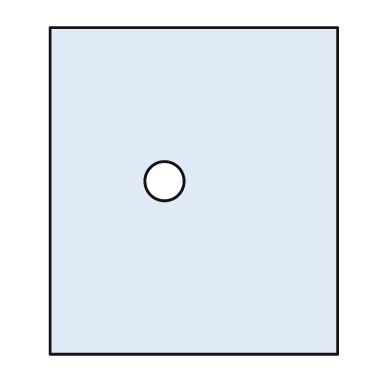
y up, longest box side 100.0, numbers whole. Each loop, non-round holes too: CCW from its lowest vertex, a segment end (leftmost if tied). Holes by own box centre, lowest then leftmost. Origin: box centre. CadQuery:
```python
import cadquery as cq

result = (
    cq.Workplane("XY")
    .moveTo(-44.0, -50.0)
    .lineTo(44.0, -50.0)
    .lineTo(44.0, 50.0)
    .lineTo(-44.0, 50.0)
    .close()
    .moveTo(-9.0, 3.0)
    .circle(6.0)
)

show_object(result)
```